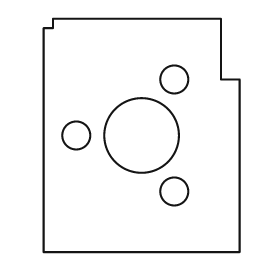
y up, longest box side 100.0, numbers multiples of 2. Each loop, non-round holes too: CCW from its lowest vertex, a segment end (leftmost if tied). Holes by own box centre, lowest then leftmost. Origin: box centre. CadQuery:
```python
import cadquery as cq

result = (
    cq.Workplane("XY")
    .moveTo(-42.0, -50.0)
    .lineTo(42.0, -50.0)
    .lineTo(42.0, 24.0)
    .lineTo(34.0, 24.0)
    .lineTo(34.0, 50.0)
    .lineTo(-38.0, 50.0)
    .lineTo(-38.0, 46.0)
    .lineTo(-42.0, 46.0)
    .close()
    .moveTo(14.0, -24.0)
    .circle(6.0)
    .moveTo(-28.0, 0.0)
    .circle(6.0)
    .moveTo(0.0, 0.0)
    .circle(16.0)
    .moveTo(14.0, 24.0)
    .circle(6.0)
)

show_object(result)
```